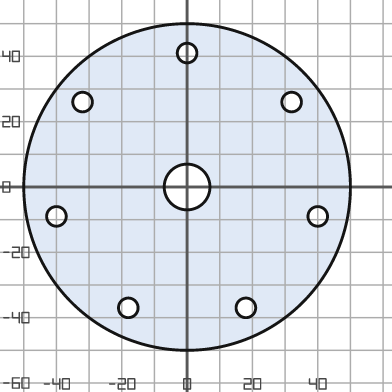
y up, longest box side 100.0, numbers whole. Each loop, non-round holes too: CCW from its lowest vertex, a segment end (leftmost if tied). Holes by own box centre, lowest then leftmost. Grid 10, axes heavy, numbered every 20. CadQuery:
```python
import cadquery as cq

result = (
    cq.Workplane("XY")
    .moveTo(0.0, 0.0)
    .circle(50.0)
    .moveTo(-18.0, -37.0)
    .circle(3.0)
    .moveTo(18.0, -37.0)
    .circle(3.0)
    .moveTo(-40.0, -9.0)
    .circle(3.0)
    .moveTo(40.0, -9.0)
    .circle(3.0)
    .moveTo(0.0, 0.0)
    .circle(7.0)
    .moveTo(-32.0, 26.0)
    .circle(3.0)
    .moveTo(32.0, 26.0)
    .circle(3.0)
    .moveTo(0.0, 41.0)
    .circle(3.0)
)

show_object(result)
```